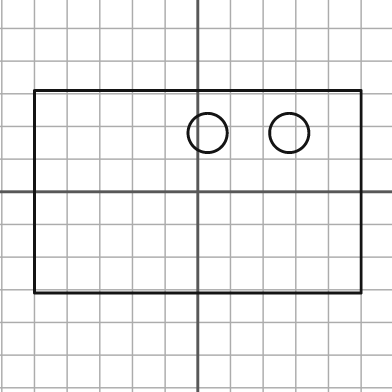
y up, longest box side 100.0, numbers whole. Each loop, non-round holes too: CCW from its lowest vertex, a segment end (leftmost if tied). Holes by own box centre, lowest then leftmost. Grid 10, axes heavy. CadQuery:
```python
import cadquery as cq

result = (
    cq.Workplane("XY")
    .moveTo(-50.0, -31.0)
    .lineTo(50.0, -31.0)
    .lineTo(50.0, 31.0)
    .lineTo(-50.0, 31.0)
    .close()
    .moveTo(3.0, 18.0)
    .circle(6.0)
    .moveTo(28.0, 18.0)
    .circle(6.0)
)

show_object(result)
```